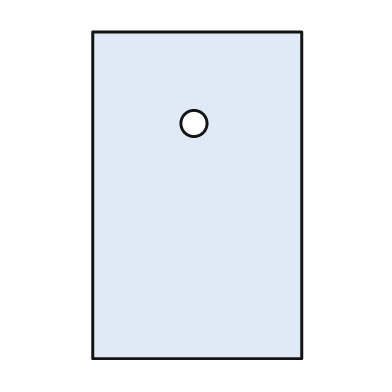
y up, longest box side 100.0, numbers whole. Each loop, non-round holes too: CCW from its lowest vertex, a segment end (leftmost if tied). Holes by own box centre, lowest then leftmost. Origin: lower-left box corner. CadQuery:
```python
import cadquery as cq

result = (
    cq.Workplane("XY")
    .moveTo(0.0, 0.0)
    .lineTo(64.0, 0.0)
    .lineTo(64.0, 100.0)
    .lineTo(0.0, 100.0)
    .close()
    .moveTo(31.0, 72.0)
    .circle(4.0)
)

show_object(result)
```